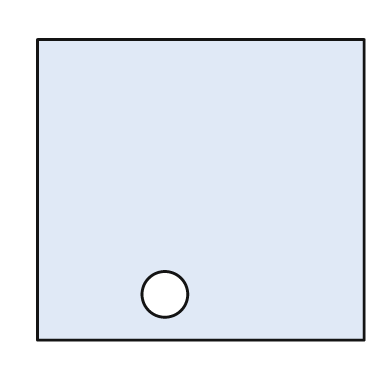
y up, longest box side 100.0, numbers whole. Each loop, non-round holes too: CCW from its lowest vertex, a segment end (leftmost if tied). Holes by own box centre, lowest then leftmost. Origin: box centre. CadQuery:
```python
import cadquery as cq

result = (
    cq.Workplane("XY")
    .moveTo(-50.0, -46.0)
    .lineTo(50.0, -46.0)
    .lineTo(50.0, 46.0)
    .lineTo(-50.0, 46.0)
    .close()
    .moveTo(-11.0, -32.0)
    .circle(7.0)
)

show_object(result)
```